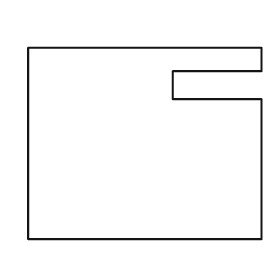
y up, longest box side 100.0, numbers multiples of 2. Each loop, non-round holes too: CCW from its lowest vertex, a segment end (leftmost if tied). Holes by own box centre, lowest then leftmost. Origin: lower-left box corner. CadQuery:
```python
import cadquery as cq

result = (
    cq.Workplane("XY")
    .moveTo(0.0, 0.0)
    .lineTo(100.0, 0.0)
    .lineTo(100.0, 60.0)
    .lineTo(62.0, 60.0)
    .lineTo(62.0, 72.0)
    .lineTo(100.0, 72.0)
    .lineTo(100.0, 82.0)
    .lineTo(0.0, 82.0)
    .close()
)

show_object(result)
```